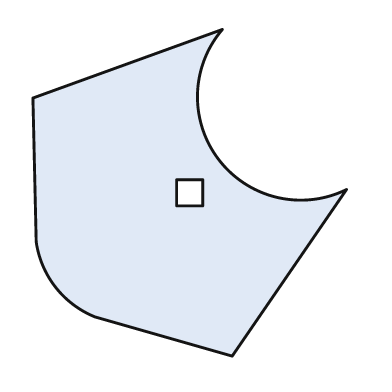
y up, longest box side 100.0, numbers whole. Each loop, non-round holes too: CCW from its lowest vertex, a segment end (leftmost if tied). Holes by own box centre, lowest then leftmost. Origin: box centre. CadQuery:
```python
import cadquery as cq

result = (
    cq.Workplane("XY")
    .moveTo(13.0, -50.0)
    .lineTo(48.0, 1.0)
    .threePointArc((9.0, 10.0), (10.0, 50.0))
    .lineTo(-48.0, 29.0)
    .lineTo(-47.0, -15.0)
    .threePointArc((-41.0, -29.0), (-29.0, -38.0))
    .close()
    .moveTo(-4.0, -4.0)
    .lineTo(4.0, -4.0)
    .lineTo(4.0, 4.0)
    .lineTo(-4.0, 4.0)
    .close()
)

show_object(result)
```